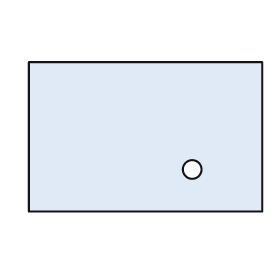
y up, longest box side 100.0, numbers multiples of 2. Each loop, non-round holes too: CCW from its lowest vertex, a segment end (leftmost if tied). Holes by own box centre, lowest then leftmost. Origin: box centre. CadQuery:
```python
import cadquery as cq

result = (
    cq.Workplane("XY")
    .moveTo(-50.0, -32.0)
    .lineTo(50.0, -32.0)
    .lineTo(50.0, 32.0)
    .lineTo(-50.0, 32.0)
    .close()
    .moveTo(20.0, -14.0)
    .circle(4.0)
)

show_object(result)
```